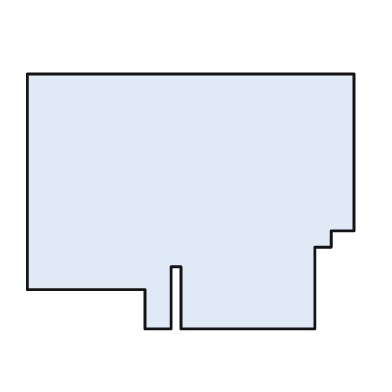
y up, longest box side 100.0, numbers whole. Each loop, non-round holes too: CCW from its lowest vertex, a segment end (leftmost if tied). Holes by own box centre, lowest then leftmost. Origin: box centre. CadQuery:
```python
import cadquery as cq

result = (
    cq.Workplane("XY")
    .moveTo(-14.0, -39.0)
    .lineTo(-6.0, -39.0)
    .lineTo(-6.0, -20.0)
    .lineTo(-3.0, -20.0)
    .lineTo(-3.0, -39.0)
    .lineTo(38.0, -39.0)
    .lineTo(38.0, -14.0)
    .lineTo(43.0, -14.0)
    .lineTo(43.0, -9.0)
    .lineTo(50.0, -9.0)
    .lineTo(50.0, 39.0)
    .lineTo(-50.0, 39.0)
    .lineTo(-50.0, -27.0)
    .lineTo(-14.0, -27.0)
    .close()
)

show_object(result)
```